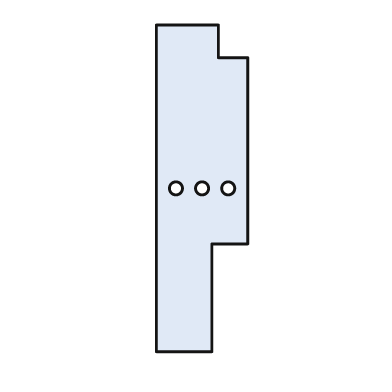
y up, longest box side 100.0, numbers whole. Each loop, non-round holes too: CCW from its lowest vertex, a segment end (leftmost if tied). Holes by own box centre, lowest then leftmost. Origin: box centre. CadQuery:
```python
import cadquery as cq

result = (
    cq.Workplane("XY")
    .moveTo(-14.0, -50.0)
    .lineTo(3.0, -50.0)
    .lineTo(3.0, -17.0)
    .lineTo(14.0, -17.0)
    .lineTo(14.0, 40.0)
    .lineTo(5.0, 40.0)
    .lineTo(5.0, 50.0)
    .lineTo(-14.0, 50.0)
    .close()
    .moveTo(-8.0, 0.0)
    .circle(2.0)
    .moveTo(0.0, 0.0)
    .circle(2.0)
    .moveTo(8.0, 0.0)
    .circle(2.0)
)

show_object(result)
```